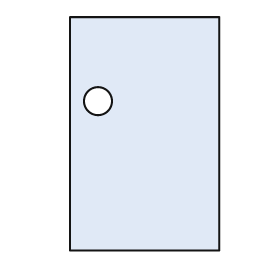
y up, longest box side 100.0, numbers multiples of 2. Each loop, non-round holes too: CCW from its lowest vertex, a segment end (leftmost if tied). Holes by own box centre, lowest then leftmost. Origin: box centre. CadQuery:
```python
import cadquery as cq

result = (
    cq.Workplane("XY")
    .moveTo(-32.0, -50.0)
    .lineTo(32.0, -50.0)
    .lineTo(32.0, 50.0)
    .lineTo(-32.0, 50.0)
    .close()
    .moveTo(-20.0, 14.0)
    .circle(6.0)
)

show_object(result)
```